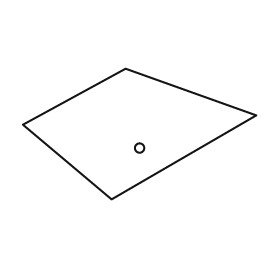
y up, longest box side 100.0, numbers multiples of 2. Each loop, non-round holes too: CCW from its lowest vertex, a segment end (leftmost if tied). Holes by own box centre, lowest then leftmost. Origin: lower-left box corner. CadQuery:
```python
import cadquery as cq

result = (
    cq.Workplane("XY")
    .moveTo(38.0, 0.0)
    .lineTo(100.0, 36.0)
    .lineTo(44.0, 56.0)
    .lineTo(0.0, 32.0)
    .close()
    .moveTo(50.0, 22.0)
    .circle(2.0)
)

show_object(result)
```